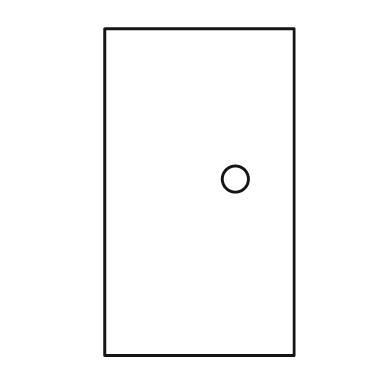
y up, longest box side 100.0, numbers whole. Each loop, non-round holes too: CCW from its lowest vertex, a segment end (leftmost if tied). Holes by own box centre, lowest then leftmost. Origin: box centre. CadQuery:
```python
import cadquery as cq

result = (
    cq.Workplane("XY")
    .moveTo(-29.0, -50.0)
    .lineTo(29.0, -50.0)
    .lineTo(29.0, 50.0)
    .lineTo(-29.0, 50.0)
    .close()
    .moveTo(11.0, 4.0)
    .circle(4.0)
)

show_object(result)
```